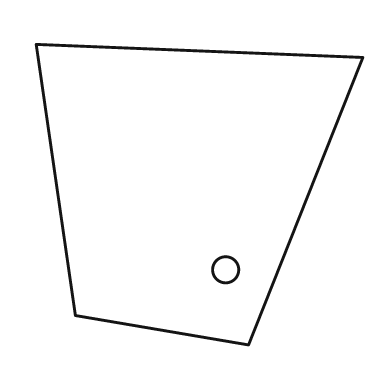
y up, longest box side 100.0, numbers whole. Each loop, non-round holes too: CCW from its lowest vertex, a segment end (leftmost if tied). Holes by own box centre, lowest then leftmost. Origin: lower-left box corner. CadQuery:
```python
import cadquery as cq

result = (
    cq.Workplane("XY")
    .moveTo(65.0, 0.0)
    .lineTo(100.0, 88.0)
    .lineTo(0.0, 92.0)
    .lineTo(12.0, 9.0)
    .close()
    .moveTo(58.0, 23.0)
    .circle(4.0)
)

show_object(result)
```